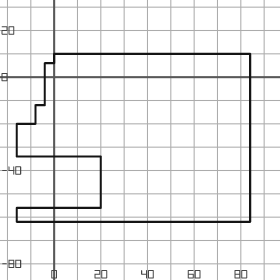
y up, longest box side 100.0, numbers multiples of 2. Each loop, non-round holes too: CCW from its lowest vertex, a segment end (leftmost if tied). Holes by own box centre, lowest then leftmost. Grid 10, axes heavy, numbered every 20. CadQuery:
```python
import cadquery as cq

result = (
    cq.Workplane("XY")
    .moveTo(-16.0, -62.0)
    .lineTo(84.0, -62.0)
    .lineTo(84.0, 10.0)
    .lineTo(0.0, 10.0)
    .lineTo(0.0, 6.0)
    .lineTo(-4.0, 6.0)
    .lineTo(-4.0, -12.0)
    .lineTo(-8.0, -12.0)
    .lineTo(-8.0, -20.0)
    .lineTo(-16.0, -20.0)
    .lineTo(-16.0, -34.0)
    .lineTo(20.0, -34.0)
    .lineTo(20.0, -56.0)
    .lineTo(-16.0, -56.0)
    .close()
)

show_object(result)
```